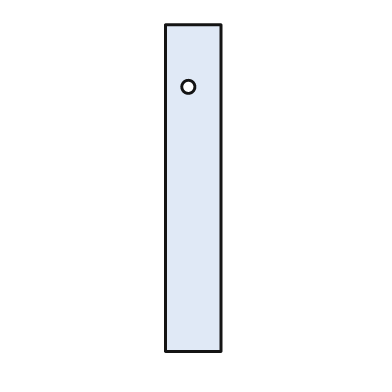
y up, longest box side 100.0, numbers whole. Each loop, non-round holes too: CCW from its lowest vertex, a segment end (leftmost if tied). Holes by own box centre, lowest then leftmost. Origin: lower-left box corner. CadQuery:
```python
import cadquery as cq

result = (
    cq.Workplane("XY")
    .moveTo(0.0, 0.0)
    .lineTo(17.0, 0.0)
    .lineTo(17.0, 100.0)
    .lineTo(0.0, 100.0)
    .close()
    .moveTo(7.0, 81.0)
    .circle(2.0)
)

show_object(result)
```